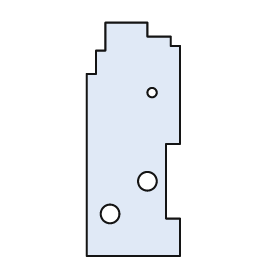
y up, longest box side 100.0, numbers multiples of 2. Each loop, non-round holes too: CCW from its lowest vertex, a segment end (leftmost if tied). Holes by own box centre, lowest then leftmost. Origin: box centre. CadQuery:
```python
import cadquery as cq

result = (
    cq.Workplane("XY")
    .moveTo(-20.0, -50.0)
    .lineTo(20.0, -50.0)
    .lineTo(20.0, -34.0)
    .lineTo(14.0, -34.0)
    .lineTo(14.0, -2.0)
    .lineTo(20.0, -2.0)
    .lineTo(20.0, 40.0)
    .lineTo(16.0, 40.0)
    .lineTo(16.0, 44.0)
    .lineTo(6.0, 44.0)
    .lineTo(6.0, 50.0)
    .lineTo(-12.0, 50.0)
    .lineTo(-12.0, 38.0)
    .lineTo(-16.0, 38.0)
    .lineTo(-16.0, 28.0)
    .lineTo(-20.0, 28.0)
    .close()
    .moveTo(-10.0, -32.0)
    .circle(4.0)
    .moveTo(6.0, -18.0)
    .circle(4.0)
    .moveTo(8.0, 20.0)
    .circle(2.0)
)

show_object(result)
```